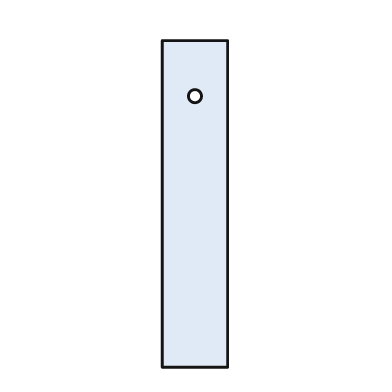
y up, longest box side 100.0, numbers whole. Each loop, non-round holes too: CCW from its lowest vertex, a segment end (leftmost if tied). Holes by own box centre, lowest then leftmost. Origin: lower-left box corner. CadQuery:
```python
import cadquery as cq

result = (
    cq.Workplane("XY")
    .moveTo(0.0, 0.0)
    .lineTo(20.0, 0.0)
    .lineTo(20.0, 100.0)
    .lineTo(0.0, 100.0)
    .close()
    .moveTo(10.0, 83.0)
    .circle(2.0)
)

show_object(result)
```